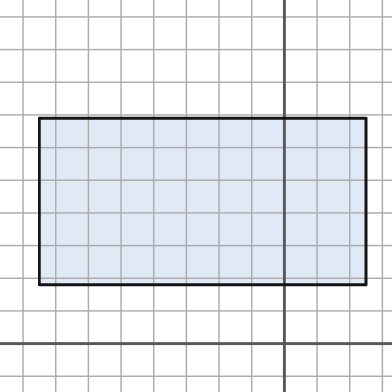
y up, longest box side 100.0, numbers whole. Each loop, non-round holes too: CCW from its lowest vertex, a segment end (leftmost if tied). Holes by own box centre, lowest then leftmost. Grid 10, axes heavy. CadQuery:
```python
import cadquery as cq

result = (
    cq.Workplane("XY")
    .moveTo(-75.0, 18.0)
    .lineTo(25.0, 18.0)
    .lineTo(25.0, 69.0)
    .lineTo(-75.0, 69.0)
    .close()
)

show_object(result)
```